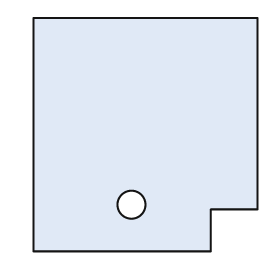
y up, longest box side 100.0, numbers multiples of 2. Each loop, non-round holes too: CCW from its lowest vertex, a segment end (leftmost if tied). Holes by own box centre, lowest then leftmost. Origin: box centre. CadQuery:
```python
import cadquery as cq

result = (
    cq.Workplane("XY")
    .moveTo(-48.0, -50.0)
    .lineTo(28.0, -50.0)
    .lineTo(28.0, -32.0)
    .lineTo(48.0, -32.0)
    .lineTo(48.0, 50.0)
    .lineTo(-48.0, 50.0)
    .close()
    .moveTo(-6.0, -30.0)
    .circle(6.0)
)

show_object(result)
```